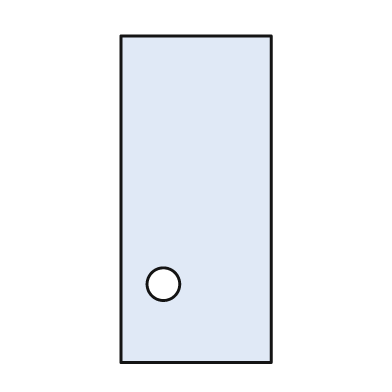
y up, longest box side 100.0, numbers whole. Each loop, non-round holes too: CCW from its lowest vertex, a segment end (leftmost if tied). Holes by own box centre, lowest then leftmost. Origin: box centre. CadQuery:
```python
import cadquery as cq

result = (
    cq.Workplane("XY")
    .moveTo(-23.0, -50.0)
    .lineTo(23.0, -50.0)
    .lineTo(23.0, 50.0)
    .lineTo(-23.0, 50.0)
    .close()
    .moveTo(-10.0, -26.0)
    .circle(5.0)
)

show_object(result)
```